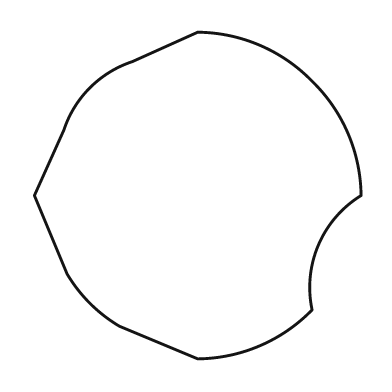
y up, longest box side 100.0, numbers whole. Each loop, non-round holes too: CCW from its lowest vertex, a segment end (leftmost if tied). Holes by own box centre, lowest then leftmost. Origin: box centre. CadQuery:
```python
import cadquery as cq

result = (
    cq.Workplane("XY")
    .moveTo(0.0, -50.0)
    .threePointArc((19.0, -46.0), (35.0, -35.0))
    .threePointArc((37.0, -15.0), (50.0, 0.0))
    .threePointArc((46.0, 19.0), (35.0, 35.0))
    .threePointArc((19.0, 46.0), (0.0, 50.0))
    .lineTo(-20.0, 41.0)
    .threePointArc((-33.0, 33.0), (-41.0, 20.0))
    .lineTo(-50.0, 0.0)
    .lineTo(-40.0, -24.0)
    .threePointArc((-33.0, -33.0), (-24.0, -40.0))
    .close()
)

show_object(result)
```